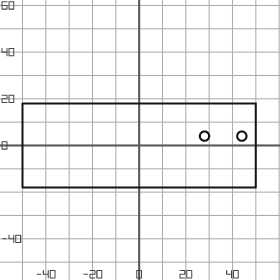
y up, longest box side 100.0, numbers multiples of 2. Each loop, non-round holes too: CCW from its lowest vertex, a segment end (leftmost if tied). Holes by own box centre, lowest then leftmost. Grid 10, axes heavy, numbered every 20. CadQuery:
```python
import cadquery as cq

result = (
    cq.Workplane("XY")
    .moveTo(-50.0, -18.0)
    .lineTo(50.0, -18.0)
    .lineTo(50.0, 18.0)
    .lineTo(-50.0, 18.0)
    .close()
    .moveTo(28.0, 4.0)
    .circle(2.0)
    .moveTo(44.0, 4.0)
    .circle(2.0)
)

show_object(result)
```